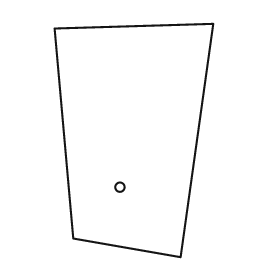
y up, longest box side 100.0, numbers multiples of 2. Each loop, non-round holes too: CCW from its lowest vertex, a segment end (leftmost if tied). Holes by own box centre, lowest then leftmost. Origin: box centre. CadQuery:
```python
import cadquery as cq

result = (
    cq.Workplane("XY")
    .moveTo(20.0, -50.0)
    .lineTo(34.0, 50.0)
    .lineTo(-34.0, 48.0)
    .lineTo(-26.0, -42.0)
    .close()
    .moveTo(-6.0, -20.0)
    .circle(2.0)
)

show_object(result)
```